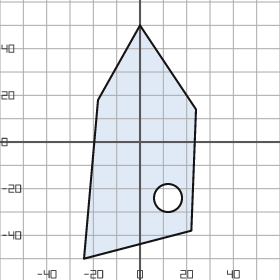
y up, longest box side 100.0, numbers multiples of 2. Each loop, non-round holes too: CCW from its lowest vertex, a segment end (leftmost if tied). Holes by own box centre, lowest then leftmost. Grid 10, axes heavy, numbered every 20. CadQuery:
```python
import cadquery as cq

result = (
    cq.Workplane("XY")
    .moveTo(-24.0, -50.0)
    .lineTo(22.0, -38.0)
    .lineTo(24.0, 14.0)
    .lineTo(0.0, 50.0)
    .lineTo(-18.0, 18.0)
    .close()
    .moveTo(12.0, -24.0)
    .circle(6.0)
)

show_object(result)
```